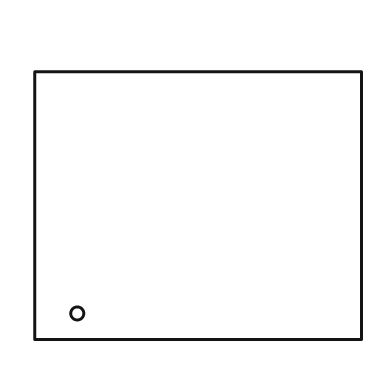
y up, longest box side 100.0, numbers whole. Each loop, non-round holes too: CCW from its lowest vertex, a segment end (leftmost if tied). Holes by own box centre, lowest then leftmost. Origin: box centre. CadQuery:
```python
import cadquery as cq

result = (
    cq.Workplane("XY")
    .moveTo(-50.0, -41.0)
    .lineTo(50.0, -41.0)
    .lineTo(50.0, 41.0)
    .lineTo(-50.0, 41.0)
    .close()
    .moveTo(-37.0, -33.0)
    .circle(2.0)
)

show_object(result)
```